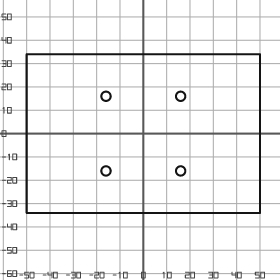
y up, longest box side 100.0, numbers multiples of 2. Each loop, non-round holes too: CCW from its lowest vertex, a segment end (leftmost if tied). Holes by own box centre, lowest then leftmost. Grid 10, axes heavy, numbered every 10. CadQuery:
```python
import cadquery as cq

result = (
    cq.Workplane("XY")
    .moveTo(-50.0, -34.0)
    .lineTo(50.0, -34.0)
    .lineTo(50.0, 34.0)
    .lineTo(-50.0, 34.0)
    .close()
    .moveTo(-16.0, -16.0)
    .circle(2.0)
    .moveTo(16.0, -16.0)
    .circle(2.0)
    .moveTo(-16.0, 16.0)
    .circle(2.0)
    .moveTo(16.0, 16.0)
    .circle(2.0)
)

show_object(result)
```